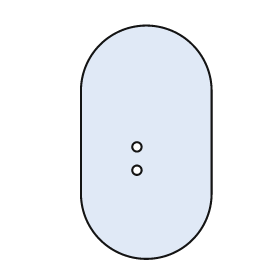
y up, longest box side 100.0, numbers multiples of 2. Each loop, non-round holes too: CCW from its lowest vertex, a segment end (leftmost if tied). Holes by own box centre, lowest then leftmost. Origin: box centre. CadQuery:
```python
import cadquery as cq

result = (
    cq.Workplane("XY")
    .moveTo(-28.0, -22.0)
    .threePointArc((0.0, -50.0), (28.0, -22.0))
    .lineTo(28.0, 22.0)
    .threePointArc((0.0, 50.0), (-28.0, 22.0))
    .close()
    .moveTo(-4.0, -12.0)
    .circle(2.0)
    .moveTo(-4.0, -2.0)
    .circle(2.0)
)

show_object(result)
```